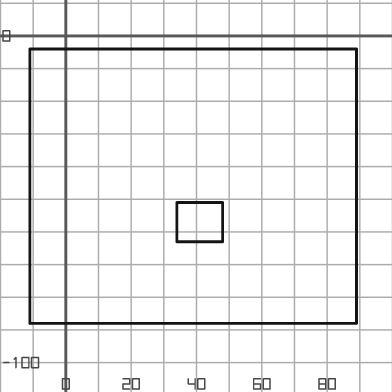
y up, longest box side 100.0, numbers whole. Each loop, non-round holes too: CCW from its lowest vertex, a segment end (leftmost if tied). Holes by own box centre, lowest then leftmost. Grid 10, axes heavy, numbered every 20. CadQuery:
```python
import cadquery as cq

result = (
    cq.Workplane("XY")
    .moveTo(-11.0, -88.0)
    .lineTo(89.0, -88.0)
    .lineTo(89.0, -4.0)
    .lineTo(-11.0, -4.0)
    .close()
    .moveTo(34.0, -63.0)
    .lineTo(48.0, -63.0)
    .lineTo(48.0, -51.0)
    .lineTo(34.0, -51.0)
    .close()
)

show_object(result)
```